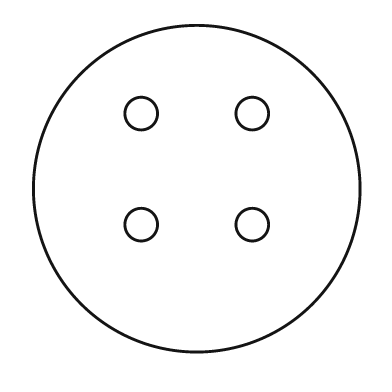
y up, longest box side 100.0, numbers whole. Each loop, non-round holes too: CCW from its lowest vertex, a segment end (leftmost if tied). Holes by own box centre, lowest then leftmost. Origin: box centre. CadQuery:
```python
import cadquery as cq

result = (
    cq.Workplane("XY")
    .moveTo(0.0, 0.0)
    .circle(50.0)
    .moveTo(-17.0, -11.0)
    .circle(5.0)
    .moveTo(17.0, -11.0)
    .circle(5.0)
    .moveTo(-17.0, 23.0)
    .circle(5.0)
    .moveTo(17.0, 23.0)
    .circle(5.0)
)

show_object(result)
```